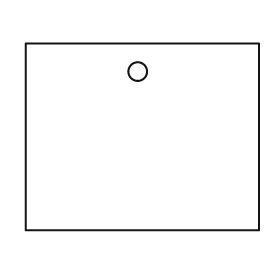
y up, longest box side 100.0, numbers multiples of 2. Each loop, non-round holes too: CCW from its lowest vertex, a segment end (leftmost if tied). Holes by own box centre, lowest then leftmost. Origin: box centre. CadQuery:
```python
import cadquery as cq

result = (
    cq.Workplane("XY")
    .moveTo(-50.0, -40.0)
    .lineTo(50.0, -40.0)
    .lineTo(50.0, 40.0)
    .lineTo(-50.0, 40.0)
    .close()
    .moveTo(-2.0, 28.0)
    .circle(4.0)
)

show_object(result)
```